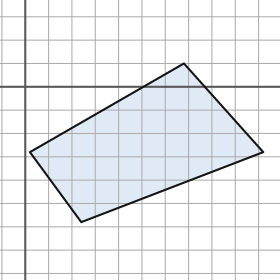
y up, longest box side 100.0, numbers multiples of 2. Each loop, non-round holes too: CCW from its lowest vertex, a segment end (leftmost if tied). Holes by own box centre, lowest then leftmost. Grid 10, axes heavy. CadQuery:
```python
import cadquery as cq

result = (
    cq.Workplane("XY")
    .moveTo(24.0, -58.0)
    .lineTo(102.0, -28.0)
    .lineTo(68.0, 10.0)
    .lineTo(2.0, -28.0)
    .close()
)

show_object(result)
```